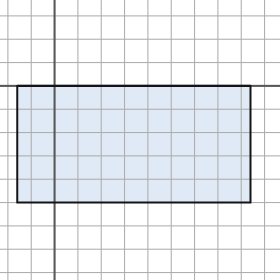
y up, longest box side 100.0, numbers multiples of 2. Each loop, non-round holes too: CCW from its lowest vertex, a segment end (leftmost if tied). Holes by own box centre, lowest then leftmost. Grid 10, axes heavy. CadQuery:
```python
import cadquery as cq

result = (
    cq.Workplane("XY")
    .moveTo(-16.0, -50.0)
    .lineTo(84.0, -50.0)
    .lineTo(84.0, 0.0)
    .lineTo(-16.0, 0.0)
    .close()
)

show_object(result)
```